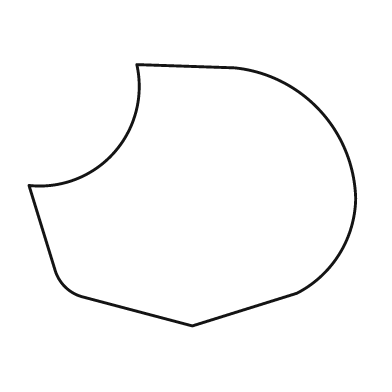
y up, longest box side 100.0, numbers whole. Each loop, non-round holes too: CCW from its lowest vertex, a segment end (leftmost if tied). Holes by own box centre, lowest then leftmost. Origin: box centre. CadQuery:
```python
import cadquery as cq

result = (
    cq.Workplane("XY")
    .moveTo(0.0, -40.0)
    .lineTo(32.0, -30.0)
    .threePointArc((45.0, -18.0), (50.0, -1.0))
    .threePointArc((39.0, 26.0), (13.0, 39.0))
    .lineTo(-17.0, 40.0)
    .threePointArc((-24.0, 13.0), (-50.0, 3.0))
    .lineTo(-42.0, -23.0)
    .threePointArc((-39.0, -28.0), (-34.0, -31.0))
    .close()
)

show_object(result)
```